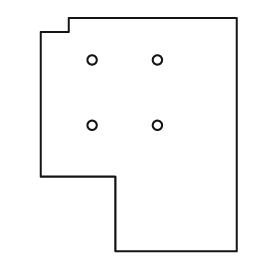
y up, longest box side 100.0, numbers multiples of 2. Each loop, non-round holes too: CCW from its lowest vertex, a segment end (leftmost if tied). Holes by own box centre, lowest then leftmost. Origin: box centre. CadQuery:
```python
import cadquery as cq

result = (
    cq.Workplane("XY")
    .moveTo(-10.0, -50.0)
    .lineTo(42.0, -50.0)
    .lineTo(42.0, 50.0)
    .lineTo(-30.0, 50.0)
    .lineTo(-30.0, 44.0)
    .lineTo(-42.0, 44.0)
    .lineTo(-42.0, -18.0)
    .lineTo(-10.0, -18.0)
    .close()
    .moveTo(-20.0, 4.0)
    .circle(2.0)
    .moveTo(8.0, 4.0)
    .circle(2.0)
    .moveTo(-20.0, 32.0)
    .circle(2.0)
    .moveTo(8.0, 32.0)
    .circle(2.0)
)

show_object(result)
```